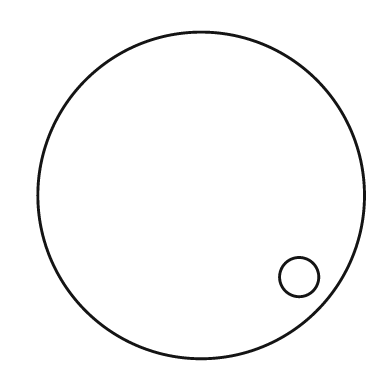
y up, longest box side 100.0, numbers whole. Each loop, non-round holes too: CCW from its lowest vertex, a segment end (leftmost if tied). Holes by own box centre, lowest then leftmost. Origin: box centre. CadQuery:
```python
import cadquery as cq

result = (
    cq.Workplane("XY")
    .moveTo(0.0, 0.0)
    .circle(50.0)
    .moveTo(30.0, -25.0)
    .circle(6.0)
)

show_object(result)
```